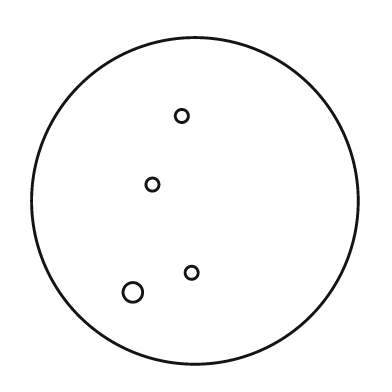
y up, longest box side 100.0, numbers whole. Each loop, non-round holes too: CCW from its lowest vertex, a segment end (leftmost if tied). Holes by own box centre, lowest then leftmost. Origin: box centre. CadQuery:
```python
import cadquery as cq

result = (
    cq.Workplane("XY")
    .moveTo(0.0, 0.0)
    .circle(50.0)
    .moveTo(-19.0, -28.0)
    .circle(3.0)
    .moveTo(-1.0, -22.0)
    .circle(2.0)
    .moveTo(-13.0, 5.0)
    .circle(2.0)
    .moveTo(-4.0, 26.0)
    .circle(2.0)
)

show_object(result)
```